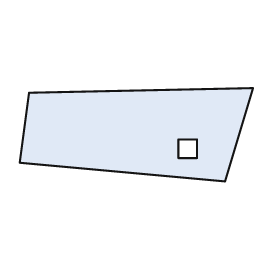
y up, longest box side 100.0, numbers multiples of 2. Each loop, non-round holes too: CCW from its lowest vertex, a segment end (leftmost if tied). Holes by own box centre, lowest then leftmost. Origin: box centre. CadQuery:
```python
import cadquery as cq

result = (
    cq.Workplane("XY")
    .moveTo(38.0, -20.0)
    .lineTo(50.0, 20.0)
    .lineTo(-46.0, 18.0)
    .lineTo(-50.0, -12.0)
    .close()
    .moveTo(18.0, -10.0)
    .lineTo(26.0, -10.0)
    .lineTo(26.0, -2.0)
    .lineTo(18.0, -2.0)
    .close()
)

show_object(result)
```